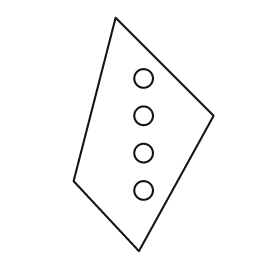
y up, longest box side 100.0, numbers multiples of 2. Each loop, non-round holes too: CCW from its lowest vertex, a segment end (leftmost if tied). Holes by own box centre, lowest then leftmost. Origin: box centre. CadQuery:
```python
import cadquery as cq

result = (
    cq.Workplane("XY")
    .moveTo(-2.0, -50.0)
    .lineTo(30.0, 8.0)
    .lineTo(-12.0, 50.0)
    .lineTo(-30.0, -20.0)
    .close()
    .moveTo(0.0, -24.0)
    .circle(4.0)
    .moveTo(0.0, -8.0)
    .circle(4.0)
    .moveTo(0.0, 8.0)
    .circle(4.0)
    .moveTo(0.0, 24.0)
    .circle(4.0)
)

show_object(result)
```